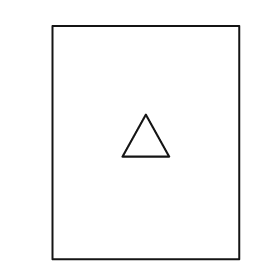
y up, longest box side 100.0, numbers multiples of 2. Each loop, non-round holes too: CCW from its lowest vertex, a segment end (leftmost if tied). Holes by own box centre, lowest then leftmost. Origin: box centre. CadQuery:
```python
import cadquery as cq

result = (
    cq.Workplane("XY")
    .moveTo(-40.0, -50.0)
    .lineTo(40.0, -50.0)
    .lineTo(40.0, 50.0)
    .lineTo(-40.0, 50.0)
    .close()
    .moveTo(-10.0, -6.0)
    .lineTo(10.0, -6.0)
    .lineTo(0.0, 12.0)
    .close()
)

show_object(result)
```